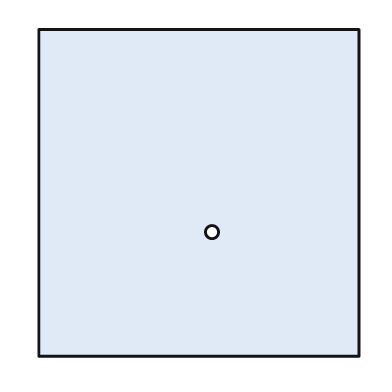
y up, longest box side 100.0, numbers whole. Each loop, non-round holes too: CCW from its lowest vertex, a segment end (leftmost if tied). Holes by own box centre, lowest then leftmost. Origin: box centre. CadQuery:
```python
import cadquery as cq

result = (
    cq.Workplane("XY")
    .moveTo(-49.0, -50.0)
    .lineTo(49.0, -50.0)
    .lineTo(49.0, 50.0)
    .lineTo(-49.0, 50.0)
    .close()
    .moveTo(4.0, -12.0)
    .circle(2.0)
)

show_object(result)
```